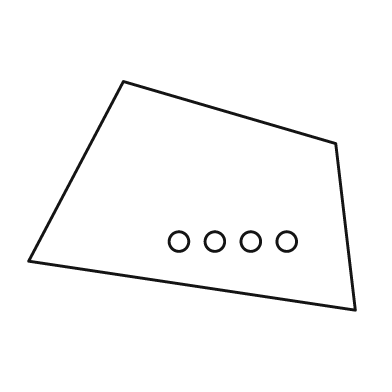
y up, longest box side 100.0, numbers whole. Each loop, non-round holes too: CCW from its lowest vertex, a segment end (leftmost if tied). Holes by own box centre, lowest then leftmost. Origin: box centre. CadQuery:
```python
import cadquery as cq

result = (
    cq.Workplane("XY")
    .moveTo(50.0, -35.0)
    .lineTo(44.0, 16.0)
    .lineTo(-21.0, 35.0)
    .lineTo(-50.0, -20.0)
    .close()
    .moveTo(-4.0, -14.0)
    .circle(3.0)
    .moveTo(7.0, -14.0)
    .circle(3.0)
    .moveTo(18.0, -14.0)
    .circle(3.0)
    .moveTo(29.0, -14.0)
    .circle(3.0)
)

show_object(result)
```